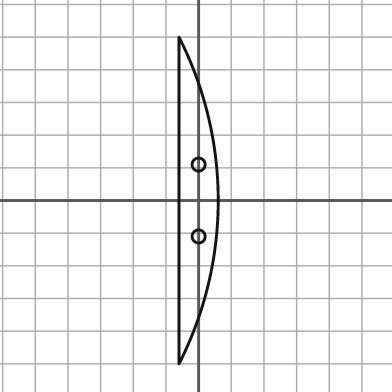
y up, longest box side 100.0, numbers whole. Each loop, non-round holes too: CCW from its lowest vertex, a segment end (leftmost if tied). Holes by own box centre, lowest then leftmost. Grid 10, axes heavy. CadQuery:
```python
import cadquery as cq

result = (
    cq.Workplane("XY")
    .moveTo(-6.0, -50.0)
    .threePointArc((6.0, 0.0), (-6.0, 50.0))
    .close()
    .moveTo(0.0, -11.0)
    .circle(2.0)
    .moveTo(0.0, 11.0)
    .circle(2.0)
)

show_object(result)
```